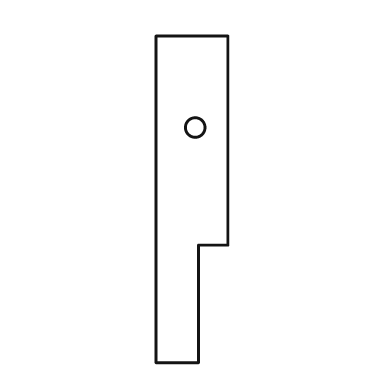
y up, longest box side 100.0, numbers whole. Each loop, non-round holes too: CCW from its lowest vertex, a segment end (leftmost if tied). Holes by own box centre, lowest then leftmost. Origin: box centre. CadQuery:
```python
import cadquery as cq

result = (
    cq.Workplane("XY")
    .moveTo(-11.0, -50.0)
    .lineTo(2.0, -50.0)
    .lineTo(2.0, -14.0)
    .lineTo(11.0, -14.0)
    .lineTo(11.0, 50.0)
    .lineTo(-11.0, 50.0)
    .close()
    .moveTo(1.0, 22.0)
    .circle(3.0)
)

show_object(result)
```